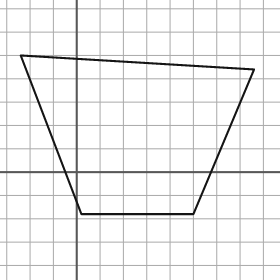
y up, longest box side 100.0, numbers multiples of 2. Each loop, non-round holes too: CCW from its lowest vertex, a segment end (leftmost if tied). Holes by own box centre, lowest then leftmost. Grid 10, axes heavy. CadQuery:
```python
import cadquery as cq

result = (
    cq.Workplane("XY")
    .moveTo(2.0, -18.0)
    .lineTo(50.0, -18.0)
    .lineTo(76.0, 44.0)
    .lineTo(-24.0, 50.0)
    .close()
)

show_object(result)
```